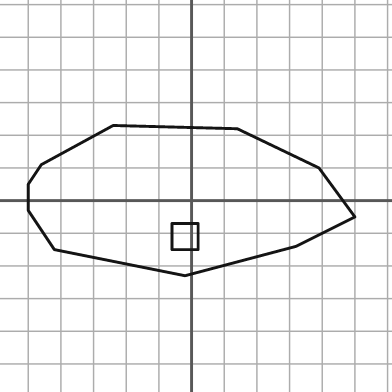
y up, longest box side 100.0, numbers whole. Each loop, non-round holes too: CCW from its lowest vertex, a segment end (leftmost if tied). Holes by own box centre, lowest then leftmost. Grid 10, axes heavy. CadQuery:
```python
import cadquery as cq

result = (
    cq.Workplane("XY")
    .moveTo(-2.0, -23.0)
    .lineTo(32.0, -14.0)
    .lineTo(50.0, -5.0)
    .lineTo(39.0, 10.0)
    .lineTo(14.0, 22.0)
    .lineTo(-24.0, 23.0)
    .lineTo(-46.0, 11.0)
    .lineTo(-50.0, 5.0)
    .lineTo(-50.0, -3.0)
    .lineTo(-42.0, -15.0)
    .close()
    .moveTo(-6.0, -15.0)
    .lineTo(2.0, -15.0)
    .lineTo(2.0, -7.0)
    .lineTo(-6.0, -7.0)
    .close()
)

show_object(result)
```